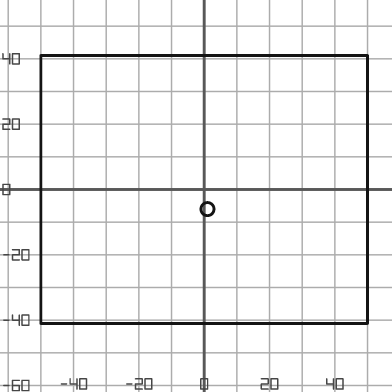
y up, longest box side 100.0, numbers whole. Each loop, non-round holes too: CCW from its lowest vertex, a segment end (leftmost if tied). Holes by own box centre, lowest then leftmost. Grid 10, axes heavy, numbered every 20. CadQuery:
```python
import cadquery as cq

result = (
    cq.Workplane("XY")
    .moveTo(-50.0, -41.0)
    .lineTo(50.0, -41.0)
    .lineTo(50.0, 41.0)
    .lineTo(-50.0, 41.0)
    .close()
    .moveTo(1.0, -6.0)
    .circle(2.0)
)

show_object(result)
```